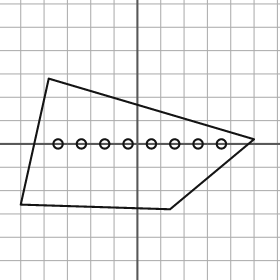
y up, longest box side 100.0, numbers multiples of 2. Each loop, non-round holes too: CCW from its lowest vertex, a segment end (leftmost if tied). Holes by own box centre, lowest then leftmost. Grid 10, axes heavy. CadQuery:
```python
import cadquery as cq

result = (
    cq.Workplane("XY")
    .moveTo(14.0, -28.0)
    .lineTo(50.0, 2.0)
    .lineTo(-38.0, 28.0)
    .lineTo(-50.0, -26.0)
    .close()
    .moveTo(-34.0, 0.0)
    .circle(2.0)
    .moveTo(-24.0, 0.0)
    .circle(2.0)
    .moveTo(-14.0, 0.0)
    .circle(2.0)
    .moveTo(-4.0, 0.0)
    .circle(2.0)
    .moveTo(6.0, 0.0)
    .circle(2.0)
    .moveTo(16.0, 0.0)
    .circle(2.0)
    .moveTo(26.0, 0.0)
    .circle(2.0)
    .moveTo(36.0, 0.0)
    .circle(2.0)
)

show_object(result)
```